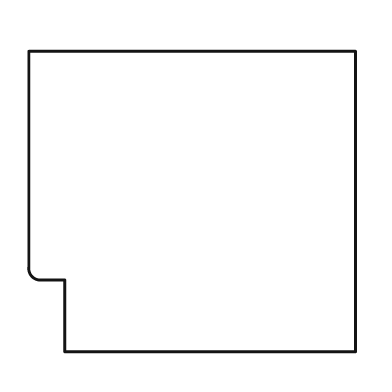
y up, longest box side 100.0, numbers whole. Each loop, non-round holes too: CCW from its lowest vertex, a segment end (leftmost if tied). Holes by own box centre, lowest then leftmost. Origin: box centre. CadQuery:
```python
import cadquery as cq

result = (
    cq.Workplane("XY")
    .moveTo(-39.0, -46.0)
    .lineTo(50.0, -46.0)
    .lineTo(50.0, 46.0)
    .lineTo(-50.0, 46.0)
    .lineTo(-50.0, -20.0)
    .threePointArc((-49.0, -23.0), (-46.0, -24.0))
    .lineTo(-39.0, -24.0)
    .close()
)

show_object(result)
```